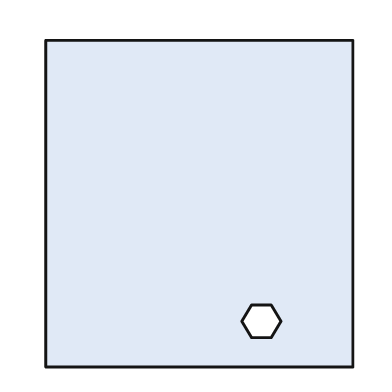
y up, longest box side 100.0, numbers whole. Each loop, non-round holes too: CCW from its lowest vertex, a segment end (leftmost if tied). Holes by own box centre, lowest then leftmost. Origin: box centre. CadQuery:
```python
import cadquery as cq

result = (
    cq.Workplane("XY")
    .moveTo(-47.0, -50.0)
    .lineTo(47.0, -50.0)
    .lineTo(47.0, 50.0)
    .lineTo(-47.0, 50.0)
    .close()
    .moveTo(16.0, -41.0)
    .lineTo(22.0, -41.0)
    .lineTo(25.0, -36.0)
    .lineTo(22.0, -31.0)
    .lineTo(16.0, -31.0)
    .lineTo(13.0, -36.0)
    .close()
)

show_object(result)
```